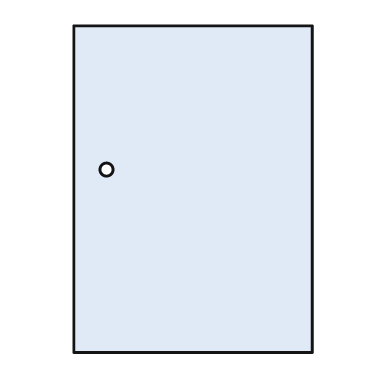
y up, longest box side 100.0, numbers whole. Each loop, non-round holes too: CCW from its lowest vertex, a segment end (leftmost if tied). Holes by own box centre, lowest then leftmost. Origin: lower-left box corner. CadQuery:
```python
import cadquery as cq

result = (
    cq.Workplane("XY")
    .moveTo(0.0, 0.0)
    .lineTo(73.0, 0.0)
    .lineTo(73.0, 100.0)
    .lineTo(0.0, 100.0)
    .close()
    .moveTo(10.0, 56.0)
    .circle(2.0)
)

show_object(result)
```